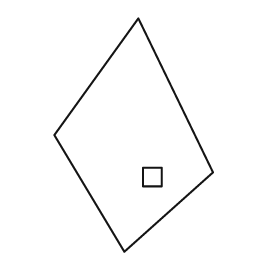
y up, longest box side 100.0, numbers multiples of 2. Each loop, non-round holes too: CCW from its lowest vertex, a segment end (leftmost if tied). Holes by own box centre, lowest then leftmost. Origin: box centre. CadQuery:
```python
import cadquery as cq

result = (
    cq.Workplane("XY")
    .moveTo(-4.0, -50.0)
    .lineTo(34.0, -16.0)
    .lineTo(2.0, 50.0)
    .lineTo(-34.0, 0.0)
    .close()
    .moveTo(4.0, -22.0)
    .lineTo(12.0, -22.0)
    .lineTo(12.0, -14.0)
    .lineTo(4.0, -14.0)
    .close()
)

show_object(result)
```